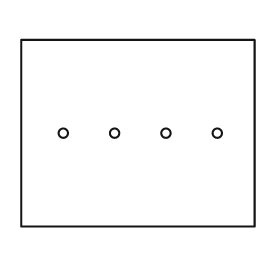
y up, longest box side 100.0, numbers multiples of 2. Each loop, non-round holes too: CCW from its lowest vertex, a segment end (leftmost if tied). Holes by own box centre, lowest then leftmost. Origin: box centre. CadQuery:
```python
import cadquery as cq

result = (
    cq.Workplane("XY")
    .moveTo(-50.0, -40.0)
    .lineTo(50.0, -40.0)
    .lineTo(50.0, 40.0)
    .lineTo(-50.0, 40.0)
    .close()
    .moveTo(-32.0, 0.0)
    .circle(2.0)
    .moveTo(-10.0, 0.0)
    .circle(2.0)
    .moveTo(12.0, 0.0)
    .circle(2.0)
    .moveTo(34.0, 0.0)
    .circle(2.0)
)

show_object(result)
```